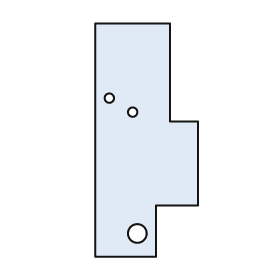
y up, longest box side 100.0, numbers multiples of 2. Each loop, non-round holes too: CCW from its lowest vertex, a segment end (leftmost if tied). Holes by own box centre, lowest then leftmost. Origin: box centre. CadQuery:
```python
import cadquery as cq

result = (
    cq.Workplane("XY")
    .moveTo(-22.0, -50.0)
    .lineTo(4.0, -50.0)
    .lineTo(4.0, -28.0)
    .lineTo(22.0, -28.0)
    .lineTo(22.0, 8.0)
    .lineTo(10.0, 8.0)
    .lineTo(10.0, 50.0)
    .lineTo(-22.0, 50.0)
    .close()
    .moveTo(-4.0, -40.0)
    .circle(4.0)
    .moveTo(-6.0, 12.0)
    .circle(2.0)
    .moveTo(-16.0, 18.0)
    .circle(2.0)
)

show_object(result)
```